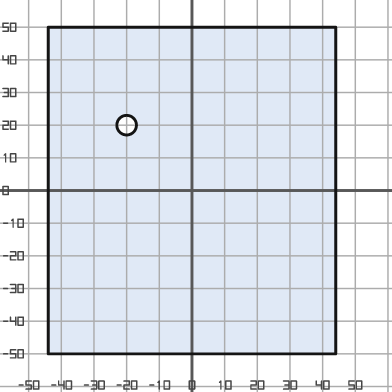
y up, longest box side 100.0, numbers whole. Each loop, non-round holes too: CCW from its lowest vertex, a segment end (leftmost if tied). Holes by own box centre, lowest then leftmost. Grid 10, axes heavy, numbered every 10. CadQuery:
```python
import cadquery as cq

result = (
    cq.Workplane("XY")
    .moveTo(-44.0, -50.0)
    .lineTo(44.0, -50.0)
    .lineTo(44.0, 50.0)
    .lineTo(-44.0, 50.0)
    .close()
    .moveTo(-20.0, 20.0)
    .circle(3.0)
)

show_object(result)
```